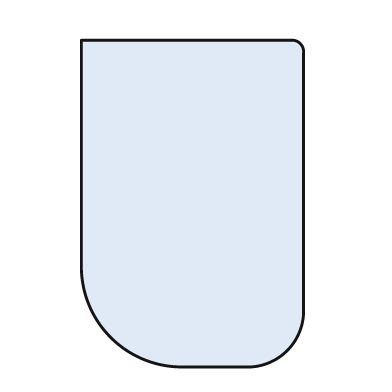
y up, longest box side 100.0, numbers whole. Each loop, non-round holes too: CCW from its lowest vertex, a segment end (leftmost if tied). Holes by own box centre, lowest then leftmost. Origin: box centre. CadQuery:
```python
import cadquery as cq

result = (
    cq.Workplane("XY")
    .moveTo(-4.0, -50.0)
    .lineTo(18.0, -50.0)
    .threePointArc((29.0, -45.0), (34.0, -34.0))
    .lineTo(34.0, 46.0)
    .threePointArc((33.0, 49.0), (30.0, 50.0))
    .lineTo(-34.0, 50.0)
    .lineTo(-34.0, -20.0)
    .threePointArc((-25.0, -41.0), (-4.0, -50.0))
    .close()
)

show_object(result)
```